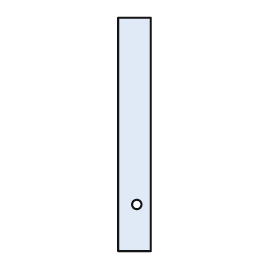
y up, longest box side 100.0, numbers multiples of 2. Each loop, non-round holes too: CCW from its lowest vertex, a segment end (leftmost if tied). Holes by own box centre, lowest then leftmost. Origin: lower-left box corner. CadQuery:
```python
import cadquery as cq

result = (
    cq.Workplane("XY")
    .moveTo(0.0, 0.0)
    .lineTo(14.0, 0.0)
    .lineTo(14.0, 100.0)
    .lineTo(0.0, 100.0)
    .close()
    .moveTo(8.0, 20.0)
    .circle(2.0)
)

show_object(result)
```